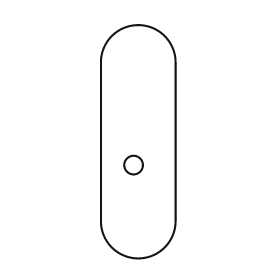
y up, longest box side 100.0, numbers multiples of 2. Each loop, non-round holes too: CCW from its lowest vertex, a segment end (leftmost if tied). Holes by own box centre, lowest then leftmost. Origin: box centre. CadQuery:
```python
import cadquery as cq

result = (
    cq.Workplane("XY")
    .moveTo(-16.0, -34.0)
    .threePointArc((0.0, -50.0), (16.0, -34.0))
    .lineTo(16.0, 34.0)
    .threePointArc((0.0, 50.0), (-16.0, 34.0))
    .close()
    .moveTo(-2.0, -10.0)
    .circle(4.0)
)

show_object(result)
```